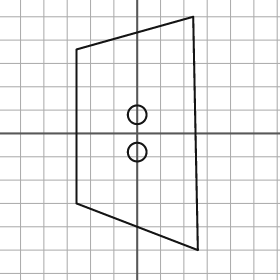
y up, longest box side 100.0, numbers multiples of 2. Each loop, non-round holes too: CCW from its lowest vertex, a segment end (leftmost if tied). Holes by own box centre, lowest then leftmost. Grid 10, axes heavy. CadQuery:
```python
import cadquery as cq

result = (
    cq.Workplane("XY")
    .moveTo(26.0, -50.0)
    .lineTo(24.0, 50.0)
    .lineTo(-26.0, 36.0)
    .lineTo(-26.0, -30.0)
    .close()
    .moveTo(0.0, -8.0)
    .circle(4.0)
    .moveTo(0.0, 8.0)
    .circle(4.0)
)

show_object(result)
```